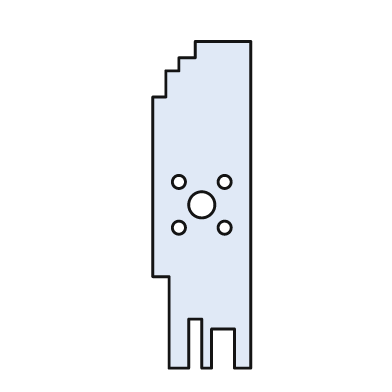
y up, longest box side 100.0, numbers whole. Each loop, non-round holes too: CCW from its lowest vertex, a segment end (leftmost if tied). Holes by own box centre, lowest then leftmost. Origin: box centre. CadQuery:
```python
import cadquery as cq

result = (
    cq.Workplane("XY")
    .moveTo(-10.0, -50.0)
    .lineTo(-4.0, -50.0)
    .lineTo(-4.0, -35.0)
    .lineTo(0.0, -35.0)
    .lineTo(0.0, -50.0)
    .lineTo(3.0, -50.0)
    .lineTo(3.0, -38.0)
    .lineTo(10.0, -38.0)
    .lineTo(10.0, -50.0)
    .lineTo(15.0, -50.0)
    .lineTo(15.0, 50.0)
    .lineTo(-2.0, 50.0)
    .lineTo(-2.0, 45.0)
    .lineTo(-7.0, 45.0)
    .lineTo(-7.0, 41.0)
    .lineTo(-11.0, 41.0)
    .lineTo(-11.0, 33.0)
    .lineTo(-15.0, 33.0)
    .lineTo(-15.0, -22.0)
    .lineTo(-10.0, -22.0)
    .close()
    .moveTo(-7.0, -7.0)
    .circle(2.0)
    .moveTo(7.0, -7.0)
    .circle(2.0)
    .moveTo(0.0, 0.0)
    .circle(4.0)
    .moveTo(-7.0, 7.0)
    .circle(2.0)
    .moveTo(7.0, 7.0)
    .circle(2.0)
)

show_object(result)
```